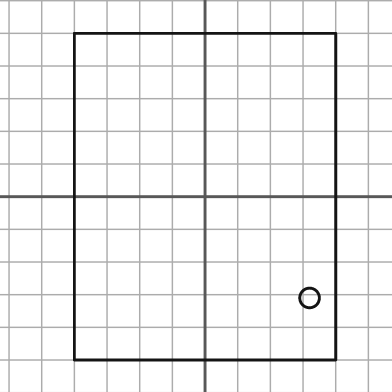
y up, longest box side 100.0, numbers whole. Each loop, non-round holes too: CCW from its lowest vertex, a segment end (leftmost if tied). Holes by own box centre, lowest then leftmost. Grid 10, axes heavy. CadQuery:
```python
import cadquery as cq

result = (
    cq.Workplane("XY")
    .moveTo(-40.0, -50.0)
    .lineTo(40.0, -50.0)
    .lineTo(40.0, 50.0)
    .lineTo(-40.0, 50.0)
    .close()
    .moveTo(32.0, -31.0)
    .circle(3.0)
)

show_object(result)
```